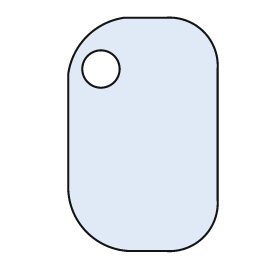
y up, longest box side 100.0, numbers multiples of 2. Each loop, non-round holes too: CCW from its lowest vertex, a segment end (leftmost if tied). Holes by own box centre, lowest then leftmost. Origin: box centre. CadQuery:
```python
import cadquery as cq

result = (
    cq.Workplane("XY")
    .moveTo(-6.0, -50.0)
    .lineTo(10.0, -50.0)
    .threePointArc((26.0, -44.0), (32.0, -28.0))
    .lineTo(32.0, 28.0)
    .threePointArc((26.0, 44.0), (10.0, 50.0))
    .lineTo(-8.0, 50.0)
    .threePointArc((-24.0, 42.0), (-32.0, 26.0))
    .lineTo(-32.0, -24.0)
    .threePointArc((-24.0, -42.0), (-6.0, -50.0))
    .close()
    .moveTo(-18.0, 28.0)
    .circle(8.0)
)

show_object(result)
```